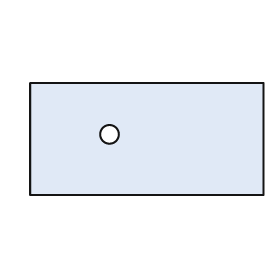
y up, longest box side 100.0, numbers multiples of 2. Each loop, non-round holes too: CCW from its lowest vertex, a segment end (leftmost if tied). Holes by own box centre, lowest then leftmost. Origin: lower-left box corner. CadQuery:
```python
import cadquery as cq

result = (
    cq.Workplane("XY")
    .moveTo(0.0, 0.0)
    .lineTo(100.0, 0.0)
    .lineTo(100.0, 48.0)
    .lineTo(0.0, 48.0)
    .close()
    .moveTo(34.0, 26.0)
    .circle(4.0)
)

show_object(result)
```